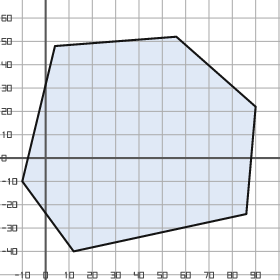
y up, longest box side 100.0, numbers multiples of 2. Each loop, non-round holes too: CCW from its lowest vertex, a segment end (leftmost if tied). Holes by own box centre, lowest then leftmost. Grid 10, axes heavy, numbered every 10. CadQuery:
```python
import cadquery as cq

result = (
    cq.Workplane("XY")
    .moveTo(12.0, -40.0)
    .lineTo(86.0, -24.0)
    .lineTo(90.0, 22.0)
    .lineTo(56.0, 52.0)
    .lineTo(4.0, 48.0)
    .lineTo(-10.0, -10.0)
    .close()
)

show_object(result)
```